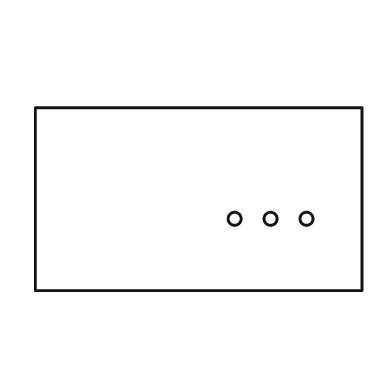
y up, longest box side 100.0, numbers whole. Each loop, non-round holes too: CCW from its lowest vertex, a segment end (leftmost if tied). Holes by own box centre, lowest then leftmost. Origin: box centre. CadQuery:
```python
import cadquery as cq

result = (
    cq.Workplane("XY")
    .moveTo(-50.0, -28.0)
    .lineTo(50.0, -28.0)
    .lineTo(50.0, 28.0)
    .lineTo(-50.0, 28.0)
    .close()
    .moveTo(11.0, -6.0)
    .circle(2.0)
    .moveTo(22.0, -6.0)
    .circle(2.0)
    .moveTo(33.0, -6.0)
    .circle(2.0)
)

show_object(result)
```